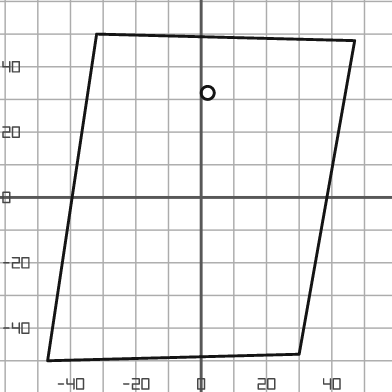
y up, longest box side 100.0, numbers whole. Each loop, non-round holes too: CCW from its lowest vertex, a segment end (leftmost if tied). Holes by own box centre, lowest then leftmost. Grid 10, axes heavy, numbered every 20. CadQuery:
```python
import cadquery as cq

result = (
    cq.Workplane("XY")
    .moveTo(-47.0, -50.0)
    .lineTo(30.0, -48.0)
    .lineTo(47.0, 48.0)
    .lineTo(-32.0, 50.0)
    .close()
    .moveTo(2.0, 32.0)
    .circle(2.0)
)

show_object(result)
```